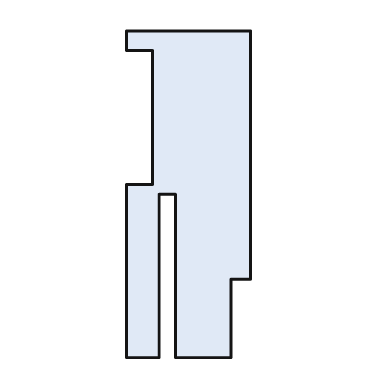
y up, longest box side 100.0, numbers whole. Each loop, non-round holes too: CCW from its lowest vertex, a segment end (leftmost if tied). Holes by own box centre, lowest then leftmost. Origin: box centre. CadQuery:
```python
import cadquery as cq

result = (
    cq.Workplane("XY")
    .moveTo(-19.0, -50.0)
    .lineTo(-9.0, -50.0)
    .lineTo(-9.0, 0.0)
    .lineTo(-4.0, 0.0)
    .lineTo(-4.0, -50.0)
    .lineTo(13.0, -50.0)
    .lineTo(13.0, -26.0)
    .lineTo(19.0, -26.0)
    .lineTo(19.0, 50.0)
    .lineTo(-19.0, 50.0)
    .lineTo(-19.0, 44.0)
    .lineTo(-11.0, 44.0)
    .lineTo(-11.0, 3.0)
    .lineTo(-19.0, 3.0)
    .close()
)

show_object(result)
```